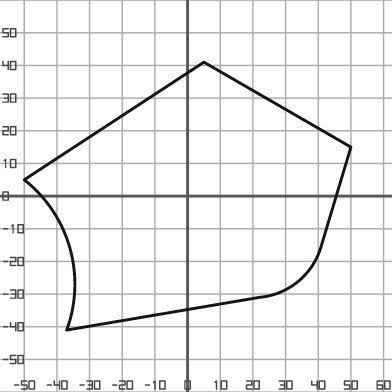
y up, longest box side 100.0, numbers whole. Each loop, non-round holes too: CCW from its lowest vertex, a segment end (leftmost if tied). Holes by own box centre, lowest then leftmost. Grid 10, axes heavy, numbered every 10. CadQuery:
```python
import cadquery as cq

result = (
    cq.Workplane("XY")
    .moveTo(-37.0, -41.0)
    .lineTo(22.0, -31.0)
    .threePointArc((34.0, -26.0), (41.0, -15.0))
    .lineTo(50.0, 15.0)
    .lineTo(5.0, 41.0)
    .lineTo(-50.0, 5.0)
    .threePointArc((-36.0, -16.0), (-37.0, -41.0))
    .close()
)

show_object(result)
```